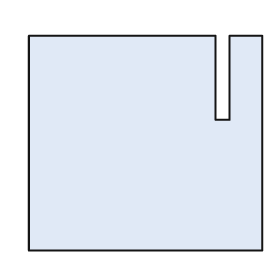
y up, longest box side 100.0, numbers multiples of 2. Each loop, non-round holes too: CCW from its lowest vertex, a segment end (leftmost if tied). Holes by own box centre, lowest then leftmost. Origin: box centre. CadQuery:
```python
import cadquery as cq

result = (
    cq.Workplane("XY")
    .moveTo(-50.0, -46.0)
    .lineTo(50.0, -46.0)
    .lineTo(50.0, 46.0)
    .lineTo(36.0, 46.0)
    .lineTo(36.0, 10.0)
    .lineTo(30.0, 10.0)
    .lineTo(30.0, 46.0)
    .lineTo(-50.0, 46.0)
    .close()
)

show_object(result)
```